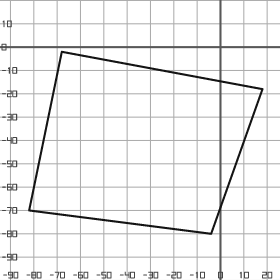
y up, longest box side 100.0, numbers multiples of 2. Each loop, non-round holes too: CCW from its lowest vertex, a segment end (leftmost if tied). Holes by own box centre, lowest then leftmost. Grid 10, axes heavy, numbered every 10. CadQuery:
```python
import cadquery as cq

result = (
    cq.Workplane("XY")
    .moveTo(-4.0, -80.0)
    .lineTo(18.0, -18.0)
    .lineTo(-68.0, -2.0)
    .lineTo(-82.0, -70.0)
    .close()
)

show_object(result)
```